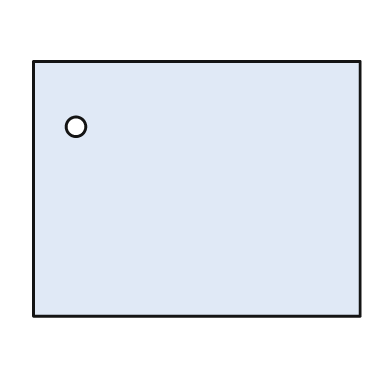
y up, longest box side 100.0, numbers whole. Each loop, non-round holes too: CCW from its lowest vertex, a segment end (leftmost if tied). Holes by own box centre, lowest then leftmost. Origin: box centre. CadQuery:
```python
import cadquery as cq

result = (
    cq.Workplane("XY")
    .moveTo(-50.0, -39.0)
    .lineTo(50.0, -39.0)
    .lineTo(50.0, 39.0)
    .lineTo(-50.0, 39.0)
    .close()
    .moveTo(-37.0, 19.0)
    .circle(3.0)
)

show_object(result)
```